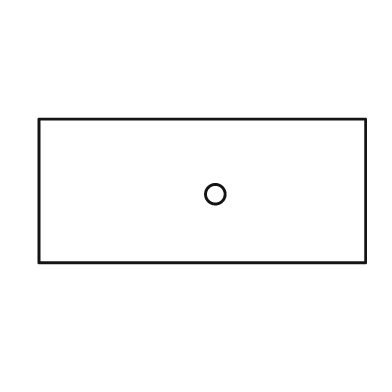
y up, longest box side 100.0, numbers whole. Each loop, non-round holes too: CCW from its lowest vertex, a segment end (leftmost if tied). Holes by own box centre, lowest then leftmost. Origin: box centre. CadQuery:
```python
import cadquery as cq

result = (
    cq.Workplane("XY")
    .moveTo(-50.0, -22.0)
    .lineTo(50.0, -22.0)
    .lineTo(50.0, 22.0)
    .lineTo(-50.0, 22.0)
    .close()
    .moveTo(4.0, -1.0)
    .circle(3.0)
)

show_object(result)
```